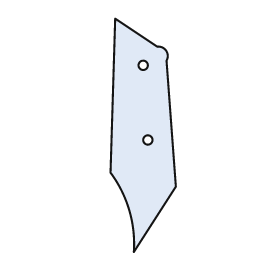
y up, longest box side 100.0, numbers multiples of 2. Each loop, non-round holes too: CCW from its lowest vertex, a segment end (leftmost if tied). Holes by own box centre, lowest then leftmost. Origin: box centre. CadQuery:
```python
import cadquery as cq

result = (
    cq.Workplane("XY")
    .moveTo(-4.0, -50.0)
    .lineTo(14.0, -22.0)
    .lineTo(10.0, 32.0)
    .threePointArc((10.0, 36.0), (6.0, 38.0))
    .lineTo(-12.0, 50.0)
    .lineTo(-14.0, -16.0)
    .threePointArc((-6.0, -32.0), (-4.0, -50.0))
    .close()
    .moveTo(2.0, -2.0)
    .circle(2.0)
    .moveTo(0.0, 30.0)
    .circle(2.0)
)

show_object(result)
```